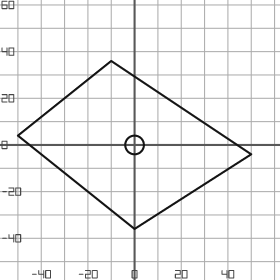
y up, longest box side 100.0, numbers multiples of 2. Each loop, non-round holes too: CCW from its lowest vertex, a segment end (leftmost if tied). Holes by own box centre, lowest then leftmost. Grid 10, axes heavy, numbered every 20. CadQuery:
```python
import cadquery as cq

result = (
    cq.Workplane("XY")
    .moveTo(0.0, -36.0)
    .lineTo(50.0, -4.0)
    .lineTo(-10.0, 36.0)
    .lineTo(-50.0, 4.0)
    .close()
    .moveTo(0.0, 0.0)
    .circle(4.0)
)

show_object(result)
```